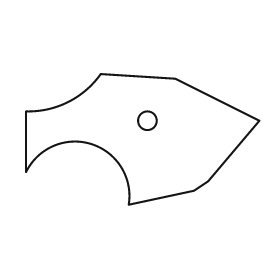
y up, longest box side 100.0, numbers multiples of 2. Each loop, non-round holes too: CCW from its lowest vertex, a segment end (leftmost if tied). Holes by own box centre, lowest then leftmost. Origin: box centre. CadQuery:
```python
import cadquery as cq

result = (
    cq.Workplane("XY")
    .moveTo(-6.0, -28.0)
    .lineTo(22.0, -22.0)
    .lineTo(28.0, -18.0)
    .lineTo(50.0, 8.0)
    .lineTo(14.0, 26.0)
    .lineTo(-18.0, 28.0)
    .threePointArc((-32.0, 16.0), (-50.0, 12.0))
    .lineTo(-50.0, -14.0)
    .threePointArc((-22.0, -2.0), (-6.0, -28.0))
    .close()
    .moveTo(2.0, 8.0)
    .circle(4.0)
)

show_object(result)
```